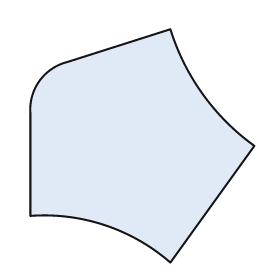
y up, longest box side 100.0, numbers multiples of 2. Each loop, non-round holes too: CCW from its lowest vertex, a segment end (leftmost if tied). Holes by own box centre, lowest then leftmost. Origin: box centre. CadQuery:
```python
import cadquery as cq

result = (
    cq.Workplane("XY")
    .moveTo(12.0, -50.0)
    .lineTo(48.0, 0.0)
    .threePointArc((26.0, 22.0), (12.0, 50.0))
    .lineTo(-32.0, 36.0)
    .threePointArc((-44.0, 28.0), (-48.0, 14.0))
    .lineTo(-48.0, -30.0)
    .threePointArc((-16.0, -34.0), (12.0, -50.0))
    .close()
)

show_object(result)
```